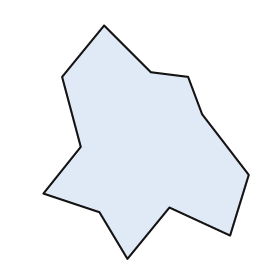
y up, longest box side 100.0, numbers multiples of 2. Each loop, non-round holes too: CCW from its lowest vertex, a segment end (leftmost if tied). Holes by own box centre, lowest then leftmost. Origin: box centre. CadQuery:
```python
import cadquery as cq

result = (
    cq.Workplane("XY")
    .moveTo(-8.0, -50.0)
    .lineTo(10.0, -28.0)
    .lineTo(36.0, -40.0)
    .lineTo(44.0, -14.0)
    .lineTo(24.0, 12.0)
    .lineTo(18.0, 28.0)
    .lineTo(2.0, 30.0)
    .lineTo(-18.0, 50.0)
    .lineTo(-36.0, 28.0)
    .lineTo(-28.0, -2.0)
    .lineTo(-44.0, -22.0)
    .lineTo(-20.0, -30.0)
    .close()
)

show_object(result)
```